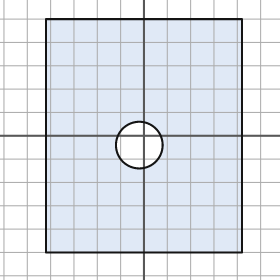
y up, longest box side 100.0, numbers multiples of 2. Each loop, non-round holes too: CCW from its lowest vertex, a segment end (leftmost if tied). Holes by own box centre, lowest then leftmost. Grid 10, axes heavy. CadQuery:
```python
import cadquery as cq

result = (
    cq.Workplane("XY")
    .moveTo(-42.0, -50.0)
    .lineTo(42.0, -50.0)
    .lineTo(42.0, 50.0)
    .lineTo(-42.0, 50.0)
    .close()
    .moveTo(-2.0, -4.0)
    .circle(10.0)
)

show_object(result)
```